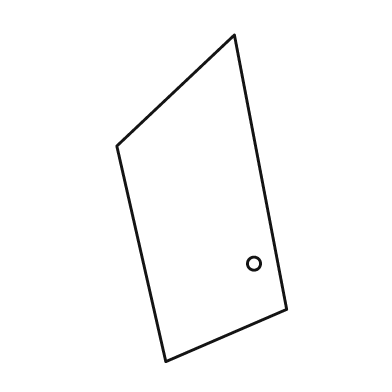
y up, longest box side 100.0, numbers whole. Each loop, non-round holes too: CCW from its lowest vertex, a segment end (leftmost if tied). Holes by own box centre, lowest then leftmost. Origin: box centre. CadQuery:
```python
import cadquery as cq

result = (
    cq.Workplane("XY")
    .moveTo(-11.0, -50.0)
    .lineTo(26.0, -34.0)
    .lineTo(10.0, 50.0)
    .lineTo(-26.0, 16.0)
    .close()
    .moveTo(16.0, -20.0)
    .circle(2.0)
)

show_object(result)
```